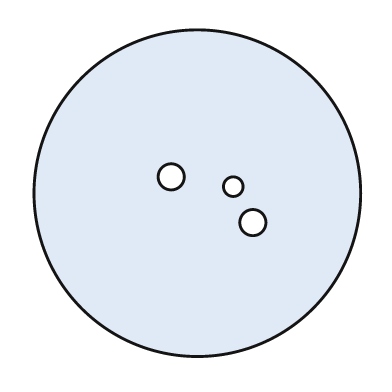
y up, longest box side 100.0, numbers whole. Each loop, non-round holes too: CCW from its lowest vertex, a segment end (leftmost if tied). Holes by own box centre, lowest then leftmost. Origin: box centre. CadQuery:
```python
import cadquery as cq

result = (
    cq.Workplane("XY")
    .moveTo(0.0, 0.0)
    .circle(50.0)
    .moveTo(17.0, -9.0)
    .circle(4.0)
    .moveTo(11.0, 2.0)
    .circle(3.0)
    .moveTo(-8.0, 5.0)
    .circle(4.0)
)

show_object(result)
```